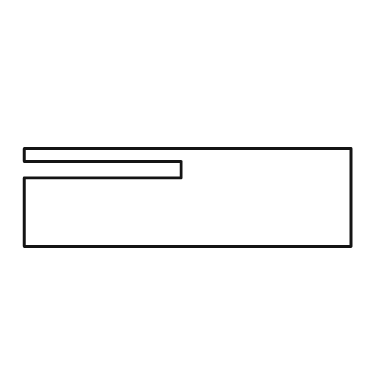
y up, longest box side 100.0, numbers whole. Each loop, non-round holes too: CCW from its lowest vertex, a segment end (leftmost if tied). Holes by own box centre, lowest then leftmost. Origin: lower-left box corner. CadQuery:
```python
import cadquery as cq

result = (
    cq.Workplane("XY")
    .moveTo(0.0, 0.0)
    .lineTo(100.0, 0.0)
    .lineTo(100.0, 30.0)
    .lineTo(0.0, 30.0)
    .lineTo(0.0, 26.0)
    .lineTo(48.0, 26.0)
    .lineTo(48.0, 21.0)
    .lineTo(0.0, 21.0)
    .close()
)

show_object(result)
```